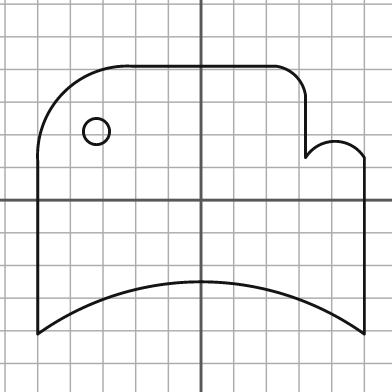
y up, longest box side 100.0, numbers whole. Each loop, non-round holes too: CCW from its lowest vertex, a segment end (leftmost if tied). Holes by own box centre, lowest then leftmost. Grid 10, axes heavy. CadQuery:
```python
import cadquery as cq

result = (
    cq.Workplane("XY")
    .moveTo(-50.0, -41.0)
    .threePointArc((0.0, -25.0), (50.0, -41.0))
    .lineTo(50.0, 13.0)
    .threePointArc((41.0, 18.0), (32.0, 13.0))
    .lineTo(32.0, 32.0)
    .threePointArc((29.0, 38.0), (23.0, 41.0))
    .lineTo(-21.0, 41.0)
    .threePointArc((-42.0, 33.0), (-50.0, 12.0))
    .close()
    .moveTo(-32.0, 21.0)
    .circle(4.0)
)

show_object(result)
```